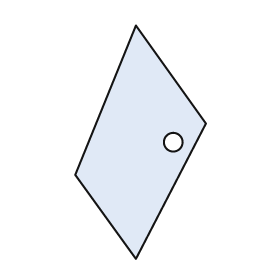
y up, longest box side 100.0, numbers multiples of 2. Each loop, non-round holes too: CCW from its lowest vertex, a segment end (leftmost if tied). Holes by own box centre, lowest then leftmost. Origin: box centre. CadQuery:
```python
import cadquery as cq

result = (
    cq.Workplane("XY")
    .moveTo(-2.0, -50.0)
    .lineTo(28.0, 8.0)
    .lineTo(-2.0, 50.0)
    .lineTo(-28.0, -14.0)
    .close()
    .moveTo(14.0, 0.0)
    .circle(4.0)
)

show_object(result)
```